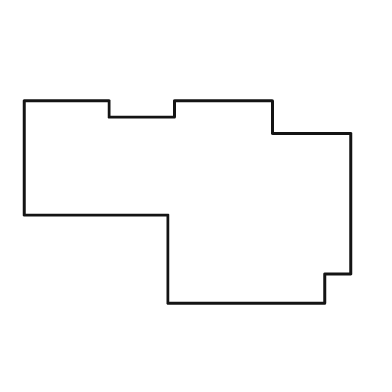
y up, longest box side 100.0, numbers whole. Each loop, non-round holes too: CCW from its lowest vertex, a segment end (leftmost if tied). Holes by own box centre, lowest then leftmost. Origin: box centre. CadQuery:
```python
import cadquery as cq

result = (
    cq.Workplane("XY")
    .moveTo(-6.0, -31.0)
    .lineTo(42.0, -31.0)
    .lineTo(42.0, -22.0)
    .lineTo(50.0, -22.0)
    .lineTo(50.0, 21.0)
    .lineTo(26.0, 21.0)
    .lineTo(26.0, 31.0)
    .lineTo(-4.0, 31.0)
    .lineTo(-4.0, 26.0)
    .lineTo(-24.0, 26.0)
    .lineTo(-24.0, 31.0)
    .lineTo(-50.0, 31.0)
    .lineTo(-50.0, -4.0)
    .lineTo(-6.0, -4.0)
    .close()
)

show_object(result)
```